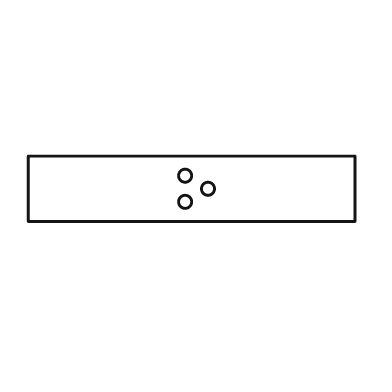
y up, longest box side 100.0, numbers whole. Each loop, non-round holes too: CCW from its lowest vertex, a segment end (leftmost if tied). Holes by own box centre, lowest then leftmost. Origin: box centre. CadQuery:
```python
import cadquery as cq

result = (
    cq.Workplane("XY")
    .moveTo(-50.0, -10.0)
    .lineTo(50.0, -10.0)
    .lineTo(50.0, 10.0)
    .lineTo(-50.0, 10.0)
    .close()
    .moveTo(-2.0, -4.0)
    .circle(2.0)
    .moveTo(5.0, 0.0)
    .circle(2.0)
    .moveTo(-2.0, 4.0)
    .circle(2.0)
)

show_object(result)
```